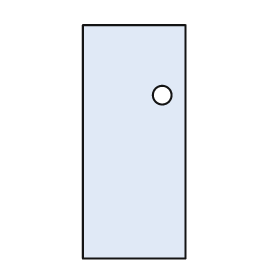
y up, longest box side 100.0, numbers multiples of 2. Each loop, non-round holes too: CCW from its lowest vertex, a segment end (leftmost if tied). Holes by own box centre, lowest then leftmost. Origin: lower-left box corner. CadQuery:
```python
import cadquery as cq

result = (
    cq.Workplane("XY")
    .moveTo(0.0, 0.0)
    .lineTo(44.0, 0.0)
    .lineTo(44.0, 100.0)
    .lineTo(0.0, 100.0)
    .close()
    .moveTo(34.0, 70.0)
    .circle(4.0)
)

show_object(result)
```